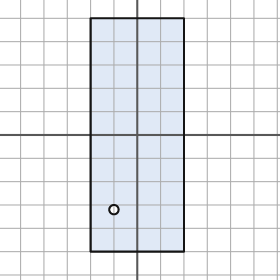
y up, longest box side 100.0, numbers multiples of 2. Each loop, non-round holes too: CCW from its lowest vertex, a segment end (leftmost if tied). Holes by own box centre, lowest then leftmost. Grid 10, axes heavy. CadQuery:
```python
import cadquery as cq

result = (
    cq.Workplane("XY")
    .moveTo(-20.0, -50.0)
    .lineTo(20.0, -50.0)
    .lineTo(20.0, 50.0)
    .lineTo(-20.0, 50.0)
    .close()
    .moveTo(-10.0, -32.0)
    .circle(2.0)
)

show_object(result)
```